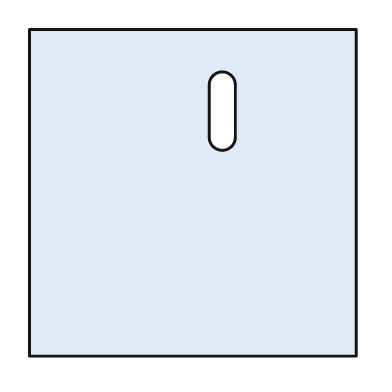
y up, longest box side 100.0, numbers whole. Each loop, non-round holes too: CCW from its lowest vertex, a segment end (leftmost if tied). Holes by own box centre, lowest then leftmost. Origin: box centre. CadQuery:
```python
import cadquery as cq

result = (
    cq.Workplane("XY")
    .moveTo(-50.0, -50.0)
    .lineTo(50.0, -50.0)
    .lineTo(50.0, 50.0)
    .lineTo(-50.0, 50.0)
    .close()
    .moveTo(5.0, 17.0)
    .threePointArc((9.0, 13.0), (13.0, 17.0))
    .lineTo(13.0, 33.0)
    .threePointArc((9.0, 37.0), (5.0, 33.0))
    .close()
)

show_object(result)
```